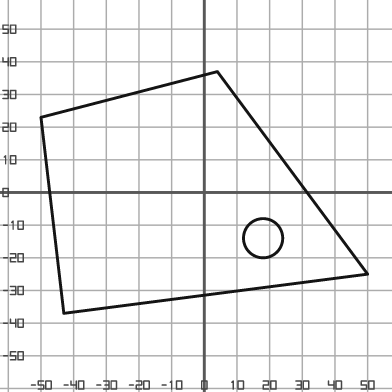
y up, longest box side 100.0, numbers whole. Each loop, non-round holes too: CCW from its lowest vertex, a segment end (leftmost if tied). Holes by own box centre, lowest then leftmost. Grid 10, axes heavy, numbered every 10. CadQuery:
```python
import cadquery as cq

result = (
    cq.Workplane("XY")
    .moveTo(-43.0, -37.0)
    .lineTo(50.0, -25.0)
    .lineTo(4.0, 37.0)
    .lineTo(-50.0, 23.0)
    .close()
    .moveTo(18.0, -14.0)
    .circle(6.0)
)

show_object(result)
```